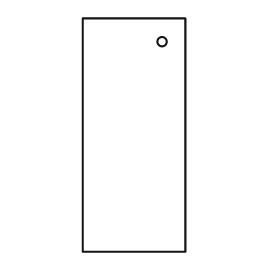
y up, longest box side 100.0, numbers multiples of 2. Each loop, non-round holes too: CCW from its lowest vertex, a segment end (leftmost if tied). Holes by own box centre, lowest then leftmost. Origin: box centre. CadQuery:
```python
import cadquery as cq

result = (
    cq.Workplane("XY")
    .moveTo(-22.0, -50.0)
    .lineTo(22.0, -50.0)
    .lineTo(22.0, 50.0)
    .lineTo(-22.0, 50.0)
    .close()
    .moveTo(12.0, 40.0)
    .circle(2.0)
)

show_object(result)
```